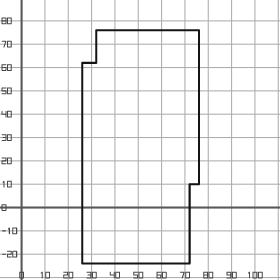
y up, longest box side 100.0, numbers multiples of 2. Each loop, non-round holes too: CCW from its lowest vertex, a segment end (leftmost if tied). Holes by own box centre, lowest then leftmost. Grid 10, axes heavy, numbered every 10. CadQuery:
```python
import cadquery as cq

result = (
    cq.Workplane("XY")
    .moveTo(26.0, -24.0)
    .lineTo(72.0, -24.0)
    .lineTo(72.0, 10.0)
    .lineTo(76.0, 10.0)
    .lineTo(76.0, 76.0)
    .lineTo(32.0, 76.0)
    .lineTo(32.0, 62.0)
    .lineTo(26.0, 62.0)
    .close()
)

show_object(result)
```